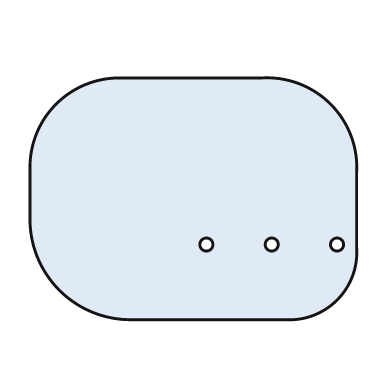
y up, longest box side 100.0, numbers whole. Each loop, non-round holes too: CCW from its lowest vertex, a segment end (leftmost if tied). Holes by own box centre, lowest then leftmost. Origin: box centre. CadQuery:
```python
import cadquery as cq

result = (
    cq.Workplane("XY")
    .moveTo(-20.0, -37.0)
    .lineTo(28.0, -37.0)
    .threePointArc((44.0, -31.0), (50.0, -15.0))
    .lineTo(50.0, 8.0)
    .threePointArc((42.0, 29.0), (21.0, 37.0))
    .lineTo(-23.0, 37.0)
    .threePointArc((-42.0, 29.0), (-50.0, 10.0))
    .lineTo(-50.0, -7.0)
    .threePointArc((-41.0, -28.0), (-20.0, -37.0))
    .close()
    .moveTo(4.0, -14.0)
    .circle(2.0)
    .moveTo(24.0, -14.0)
    .circle(2.0)
    .moveTo(44.0, -14.0)
    .circle(2.0)
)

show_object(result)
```